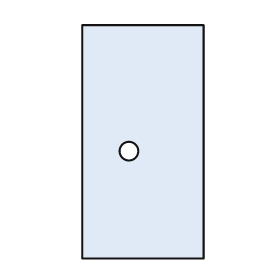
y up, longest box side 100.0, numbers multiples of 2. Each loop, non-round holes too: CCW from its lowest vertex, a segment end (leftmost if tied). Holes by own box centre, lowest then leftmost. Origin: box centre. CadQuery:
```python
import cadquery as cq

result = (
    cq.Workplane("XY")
    .moveTo(-26.0, -50.0)
    .lineTo(26.0, -50.0)
    .lineTo(26.0, 50.0)
    .lineTo(-26.0, 50.0)
    .close()
    .moveTo(-6.0, -4.0)
    .circle(4.0)
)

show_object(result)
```